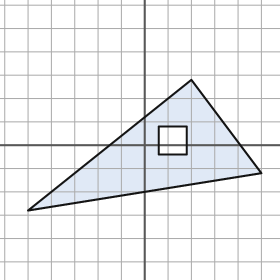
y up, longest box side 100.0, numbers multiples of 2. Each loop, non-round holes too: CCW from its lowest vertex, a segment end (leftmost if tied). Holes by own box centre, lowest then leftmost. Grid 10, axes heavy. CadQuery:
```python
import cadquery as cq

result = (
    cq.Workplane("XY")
    .moveTo(-50.0, -28.0)
    .lineTo(50.0, -12.0)
    .lineTo(20.0, 28.0)
    .close()
    .moveTo(6.0, -4.0)
    .lineTo(18.0, -4.0)
    .lineTo(18.0, 8.0)
    .lineTo(6.0, 8.0)
    .close()
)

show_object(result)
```